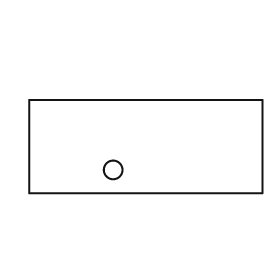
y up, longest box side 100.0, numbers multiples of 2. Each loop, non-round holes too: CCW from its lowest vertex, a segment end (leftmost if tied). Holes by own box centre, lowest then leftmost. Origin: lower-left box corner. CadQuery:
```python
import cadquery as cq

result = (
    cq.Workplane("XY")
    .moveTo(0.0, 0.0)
    .lineTo(100.0, 0.0)
    .lineTo(100.0, 40.0)
    .lineTo(0.0, 40.0)
    .close()
    .moveTo(36.0, 10.0)
    .circle(4.0)
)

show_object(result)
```